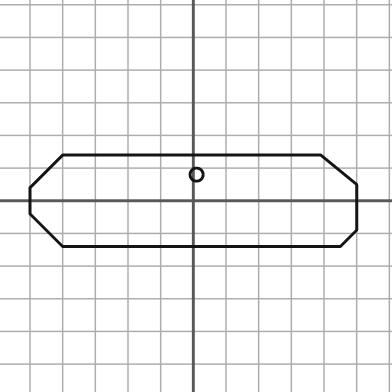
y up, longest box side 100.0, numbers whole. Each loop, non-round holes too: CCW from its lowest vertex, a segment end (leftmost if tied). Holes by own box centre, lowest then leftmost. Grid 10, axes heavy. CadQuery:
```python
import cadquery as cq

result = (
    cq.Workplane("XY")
    .moveTo(-40.0, -14.0)
    .lineTo(45.0, -14.0)
    .lineTo(50.0, -9.0)
    .lineTo(50.0, 5.0)
    .lineTo(39.0, 14.0)
    .lineTo(-40.0, 14.0)
    .lineTo(-50.0, 4.0)
    .lineTo(-50.0, -4.0)
    .close()
    .moveTo(1.0, 8.0)
    .circle(2.0)
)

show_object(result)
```